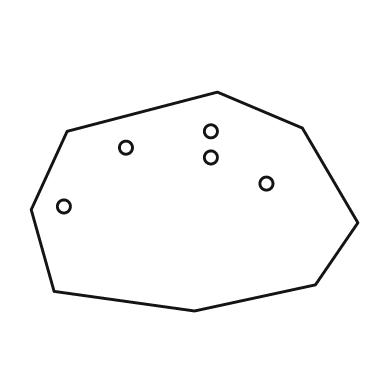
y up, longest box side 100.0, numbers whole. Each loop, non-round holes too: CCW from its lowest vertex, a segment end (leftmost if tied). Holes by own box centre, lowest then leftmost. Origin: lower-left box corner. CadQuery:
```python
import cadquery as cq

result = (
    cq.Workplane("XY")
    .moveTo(50.0, 0.0)
    .lineTo(87.0, 8.0)
    .lineTo(100.0, 27.0)
    .lineTo(83.0, 56.0)
    .lineTo(57.0, 67.0)
    .lineTo(11.0, 55.0)
    .lineTo(0.0, 31.0)
    .lineTo(7.0, 6.0)
    .close()
    .moveTo(10.0, 32.0)
    .circle(2.0)
    .moveTo(72.0, 39.0)
    .circle(2.0)
    .moveTo(55.0, 47.0)
    .circle(2.0)
    .moveTo(29.0, 50.0)
    .circle(2.0)
    .moveTo(55.0, 55.0)
    .circle(2.0)
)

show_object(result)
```